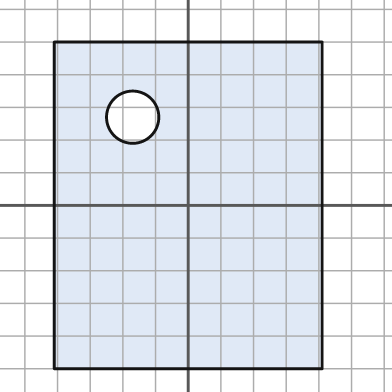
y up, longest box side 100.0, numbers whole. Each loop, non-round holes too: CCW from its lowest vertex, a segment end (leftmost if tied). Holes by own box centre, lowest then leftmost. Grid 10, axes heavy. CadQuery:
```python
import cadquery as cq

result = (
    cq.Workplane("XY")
    .moveTo(-41.0, -50.0)
    .lineTo(41.0, -50.0)
    .lineTo(41.0, 50.0)
    .lineTo(-41.0, 50.0)
    .close()
    .moveTo(-17.0, 27.0)
    .circle(8.0)
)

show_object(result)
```